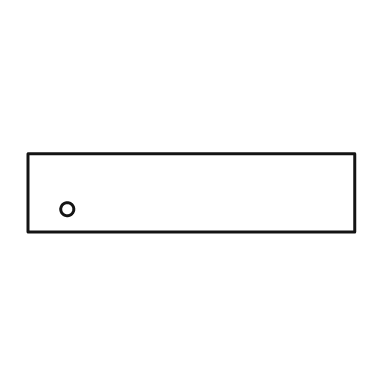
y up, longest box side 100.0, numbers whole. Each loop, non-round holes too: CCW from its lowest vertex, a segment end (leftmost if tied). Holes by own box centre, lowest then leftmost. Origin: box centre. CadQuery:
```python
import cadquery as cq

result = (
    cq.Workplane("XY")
    .moveTo(-50.0, -12.0)
    .lineTo(50.0, -12.0)
    .lineTo(50.0, 12.0)
    .lineTo(-50.0, 12.0)
    .close()
    .moveTo(-38.0, -5.0)
    .circle(2.0)
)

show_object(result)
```